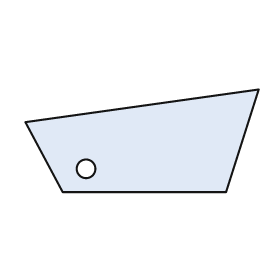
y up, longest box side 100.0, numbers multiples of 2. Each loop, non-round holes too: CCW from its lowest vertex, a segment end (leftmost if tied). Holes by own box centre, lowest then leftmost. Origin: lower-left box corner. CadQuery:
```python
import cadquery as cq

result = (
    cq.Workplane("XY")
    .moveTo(16.0, 0.0)
    .lineTo(86.0, 0.0)
    .lineTo(100.0, 44.0)
    .lineTo(0.0, 30.0)
    .close()
    .moveTo(26.0, 10.0)
    .circle(4.0)
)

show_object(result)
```